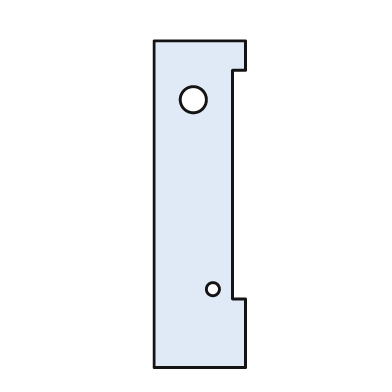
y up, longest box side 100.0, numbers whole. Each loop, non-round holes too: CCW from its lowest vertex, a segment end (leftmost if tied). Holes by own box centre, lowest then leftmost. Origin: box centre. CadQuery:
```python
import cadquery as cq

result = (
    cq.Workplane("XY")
    .moveTo(-14.0, -50.0)
    .lineTo(14.0, -50.0)
    .lineTo(14.0, -29.0)
    .lineTo(10.0, -29.0)
    .lineTo(10.0, 41.0)
    .lineTo(14.0, 41.0)
    .lineTo(14.0, 50.0)
    .lineTo(-14.0, 50.0)
    .close()
    .moveTo(4.0, -26.0)
    .circle(2.0)
    .moveTo(-2.0, 32.0)
    .circle(4.0)
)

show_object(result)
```